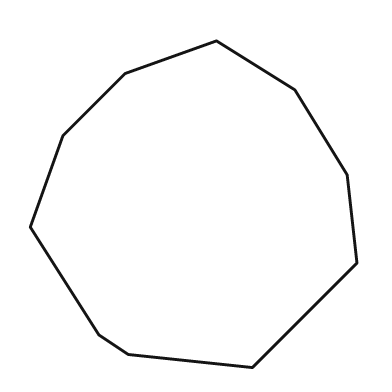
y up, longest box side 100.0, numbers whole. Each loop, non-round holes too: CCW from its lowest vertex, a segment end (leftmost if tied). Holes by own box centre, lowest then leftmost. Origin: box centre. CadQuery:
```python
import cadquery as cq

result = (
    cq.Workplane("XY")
    .moveTo(18.0, -50.0)
    .lineTo(50.0, -18.0)
    .lineTo(47.0, 9.0)
    .lineTo(31.0, 35.0)
    .lineTo(7.0, 50.0)
    .lineTo(-21.0, 40.0)
    .lineTo(-40.0, 21.0)
    .lineTo(-50.0, -7.0)
    .lineTo(-29.0, -40.0)
    .lineTo(-20.0, -46.0)
    .close()
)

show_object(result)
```